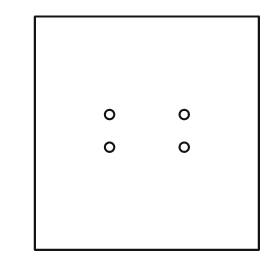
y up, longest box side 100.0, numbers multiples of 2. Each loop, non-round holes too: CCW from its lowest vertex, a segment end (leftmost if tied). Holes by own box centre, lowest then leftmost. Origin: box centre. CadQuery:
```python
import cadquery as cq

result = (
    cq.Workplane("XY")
    .moveTo(-48.0, -50.0)
    .lineTo(48.0, -50.0)
    .lineTo(48.0, 50.0)
    .lineTo(-48.0, 50.0)
    .close()
    .moveTo(-16.0, -6.0)
    .circle(2.0)
    .moveTo(16.0, -6.0)
    .circle(2.0)
    .moveTo(-16.0, 8.0)
    .circle(2.0)
    .moveTo(16.0, 8.0)
    .circle(2.0)
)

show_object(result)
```